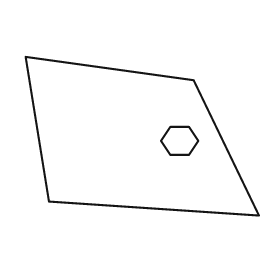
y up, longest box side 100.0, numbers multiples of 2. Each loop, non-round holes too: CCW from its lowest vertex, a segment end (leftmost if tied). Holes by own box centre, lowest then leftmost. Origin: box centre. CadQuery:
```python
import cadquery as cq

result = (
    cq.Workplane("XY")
    .moveTo(50.0, -34.0)
    .lineTo(22.0, 24.0)
    .lineTo(-50.0, 34.0)
    .lineTo(-40.0, -28.0)
    .close()
    .moveTo(12.0, -8.0)
    .lineTo(20.0, -8.0)
    .lineTo(24.0, -2.0)
    .lineTo(20.0, 4.0)
    .lineTo(12.0, 4.0)
    .lineTo(8.0, -2.0)
    .close()
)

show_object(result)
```